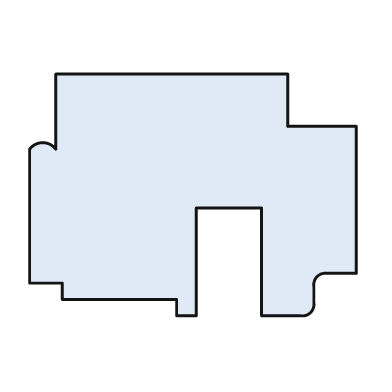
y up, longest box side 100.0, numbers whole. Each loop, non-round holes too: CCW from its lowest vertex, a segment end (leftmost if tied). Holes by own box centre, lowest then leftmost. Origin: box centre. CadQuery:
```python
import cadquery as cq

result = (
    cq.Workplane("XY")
    .moveTo(-5.0, -37.0)
    .lineTo(1.0, -37.0)
    .lineTo(1.0, -4.0)
    .lineTo(21.0, -4.0)
    .lineTo(21.0, -37.0)
    .lineTo(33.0, -37.0)
    .threePointArc((36.0, -36.0), (37.0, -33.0))
    .lineTo(37.0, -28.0)
    .threePointArc((38.0, -25.0), (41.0, -24.0))
    .lineTo(50.0, -24.0)
    .lineTo(50.0, 21.0)
    .lineTo(29.0, 21.0)
    .lineTo(29.0, 37.0)
    .lineTo(-42.0, 37.0)
    .lineTo(-42.0, 14.0)
    .threePointArc((-46.0, 16.0), (-50.0, 14.0))
    .lineTo(-50.0, -27.0)
    .lineTo(-40.0, -27.0)
    .lineTo(-40.0, -32.0)
    .lineTo(-5.0, -32.0)
    .close()
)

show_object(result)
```